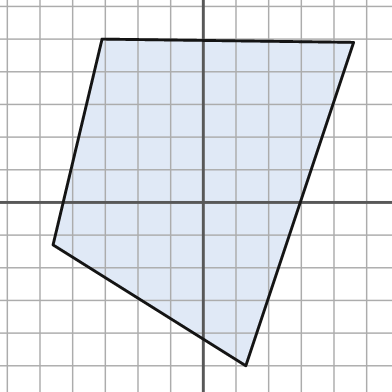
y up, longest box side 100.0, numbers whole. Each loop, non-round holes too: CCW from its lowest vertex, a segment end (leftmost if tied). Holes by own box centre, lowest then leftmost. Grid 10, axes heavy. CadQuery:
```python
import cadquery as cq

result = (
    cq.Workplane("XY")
    .moveTo(13.0, -50.0)
    .lineTo(46.0, 49.0)
    .lineTo(-31.0, 50.0)
    .lineTo(-46.0, -13.0)
    .close()
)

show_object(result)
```